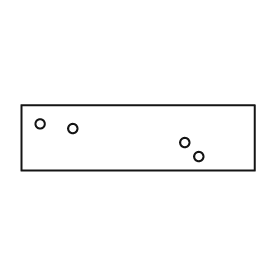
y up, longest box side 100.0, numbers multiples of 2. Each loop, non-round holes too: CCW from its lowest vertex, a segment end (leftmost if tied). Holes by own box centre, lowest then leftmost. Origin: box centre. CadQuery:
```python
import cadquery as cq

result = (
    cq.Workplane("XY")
    .moveTo(-50.0, -14.0)
    .lineTo(50.0, -14.0)
    .lineTo(50.0, 14.0)
    .lineTo(-50.0, 14.0)
    .close()
    .moveTo(26.0, -8.0)
    .circle(2.0)
    .moveTo(20.0, -2.0)
    .circle(2.0)
    .moveTo(-28.0, 4.0)
    .circle(2.0)
    .moveTo(-42.0, 6.0)
    .circle(2.0)
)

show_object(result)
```